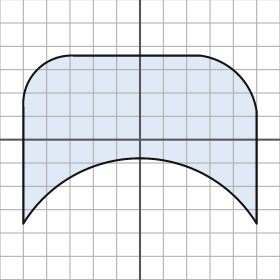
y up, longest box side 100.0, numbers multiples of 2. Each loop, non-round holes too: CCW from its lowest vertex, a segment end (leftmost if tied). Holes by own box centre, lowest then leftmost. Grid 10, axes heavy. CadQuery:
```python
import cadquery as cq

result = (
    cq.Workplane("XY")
    .moveTo(-50.0, -36.0)
    .threePointArc((0.0, -8.0), (50.0, -36.0))
    .lineTo(50.0, 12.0)
    .threePointArc((42.0, 28.0), (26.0, 36.0))
    .lineTo(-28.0, 36.0)
    .threePointArc((-44.0, 30.0), (-50.0, 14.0))
    .close()
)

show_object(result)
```